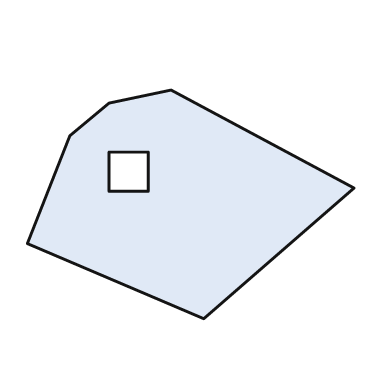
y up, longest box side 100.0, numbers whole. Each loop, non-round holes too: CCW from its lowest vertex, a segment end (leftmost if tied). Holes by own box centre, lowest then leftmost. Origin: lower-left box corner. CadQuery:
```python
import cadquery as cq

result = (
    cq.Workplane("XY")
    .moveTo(54.0, 0.0)
    .lineTo(100.0, 40.0)
    .lineTo(44.0, 70.0)
    .lineTo(25.0, 66.0)
    .lineTo(13.0, 56.0)
    .lineTo(0.0, 23.0)
    .close()
    .moveTo(25.0, 39.0)
    .lineTo(37.0, 39.0)
    .lineTo(37.0, 51.0)
    .lineTo(25.0, 51.0)
    .close()
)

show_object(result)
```